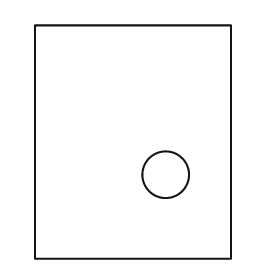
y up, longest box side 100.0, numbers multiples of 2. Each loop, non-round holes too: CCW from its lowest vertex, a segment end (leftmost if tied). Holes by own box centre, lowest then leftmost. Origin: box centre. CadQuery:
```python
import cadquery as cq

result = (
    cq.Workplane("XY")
    .moveTo(-42.0, -50.0)
    .lineTo(42.0, -50.0)
    .lineTo(42.0, 50.0)
    .lineTo(-42.0, 50.0)
    .close()
    .moveTo(14.0, -14.0)
    .circle(10.0)
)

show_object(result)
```